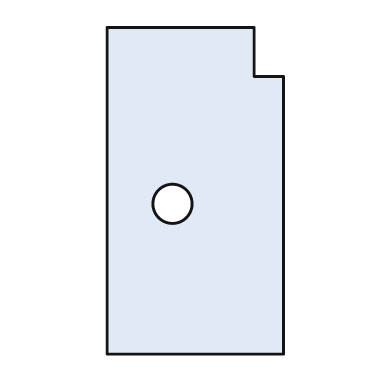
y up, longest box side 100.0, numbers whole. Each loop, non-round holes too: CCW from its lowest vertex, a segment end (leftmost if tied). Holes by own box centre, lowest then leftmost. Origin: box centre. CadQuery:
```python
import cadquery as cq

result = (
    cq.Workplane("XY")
    .moveTo(-27.0, -50.0)
    .lineTo(27.0, -50.0)
    .lineTo(27.0, 35.0)
    .lineTo(18.0, 35.0)
    .lineTo(18.0, 50.0)
    .lineTo(-27.0, 50.0)
    .close()
    .moveTo(-7.0, -4.0)
    .circle(6.0)
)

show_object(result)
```